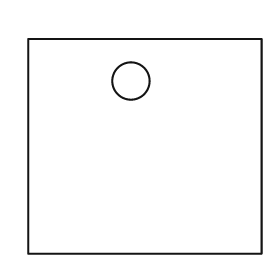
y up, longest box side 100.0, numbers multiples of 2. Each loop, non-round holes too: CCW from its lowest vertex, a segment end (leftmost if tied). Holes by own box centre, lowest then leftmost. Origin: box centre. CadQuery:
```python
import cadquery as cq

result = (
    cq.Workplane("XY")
    .moveTo(-50.0, -46.0)
    .lineTo(50.0, -46.0)
    .lineTo(50.0, 46.0)
    .lineTo(-50.0, 46.0)
    .close()
    .moveTo(-6.0, 28.0)
    .circle(8.0)
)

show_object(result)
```